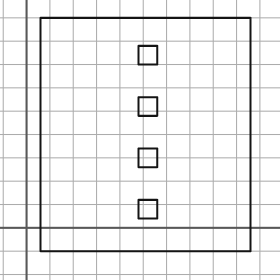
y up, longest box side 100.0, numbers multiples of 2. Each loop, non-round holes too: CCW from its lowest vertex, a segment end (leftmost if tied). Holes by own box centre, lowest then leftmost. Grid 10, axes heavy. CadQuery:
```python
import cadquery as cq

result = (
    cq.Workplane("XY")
    .moveTo(6.0, -10.0)
    .lineTo(96.0, -10.0)
    .lineTo(96.0, 90.0)
    .lineTo(6.0, 90.0)
    .close()
    .moveTo(48.0, 4.0)
    .lineTo(56.0, 4.0)
    .lineTo(56.0, 12.0)
    .lineTo(48.0, 12.0)
    .close()
    .moveTo(48.0, 26.0)
    .lineTo(56.0, 26.0)
    .lineTo(56.0, 34.0)
    .lineTo(48.0, 34.0)
    .close()
    .moveTo(48.0, 48.0)
    .lineTo(56.0, 48.0)
    .lineTo(56.0, 56.0)
    .lineTo(48.0, 56.0)
    .close()
    .moveTo(48.0, 70.0)
    .lineTo(56.0, 70.0)
    .lineTo(56.0, 78.0)
    .lineTo(48.0, 78.0)
    .close()
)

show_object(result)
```